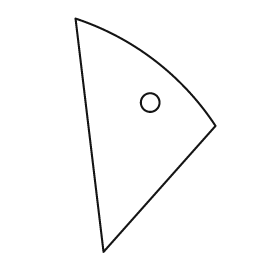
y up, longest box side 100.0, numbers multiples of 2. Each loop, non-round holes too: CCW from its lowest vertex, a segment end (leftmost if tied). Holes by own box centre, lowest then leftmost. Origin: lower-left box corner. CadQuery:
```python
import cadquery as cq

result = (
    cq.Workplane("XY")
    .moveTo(12.0, 0.0)
    .lineTo(60.0, 54.0)
    .threePointArc((34.0, 82.0), (0.0, 100.0))
    .close()
    .moveTo(32.0, 64.0)
    .circle(4.0)
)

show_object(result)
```